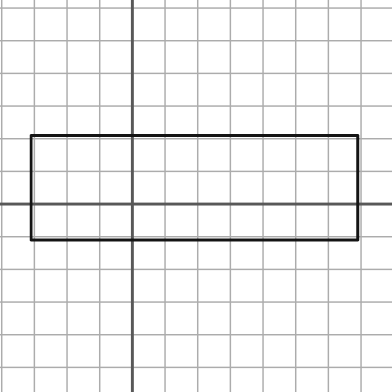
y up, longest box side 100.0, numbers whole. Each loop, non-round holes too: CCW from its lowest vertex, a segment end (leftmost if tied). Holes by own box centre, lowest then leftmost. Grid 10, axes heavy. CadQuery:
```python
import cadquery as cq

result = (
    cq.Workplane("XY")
    .moveTo(-31.0, -11.0)
    .lineTo(69.0, -11.0)
    .lineTo(69.0, 21.0)
    .lineTo(-31.0, 21.0)
    .close()
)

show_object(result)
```